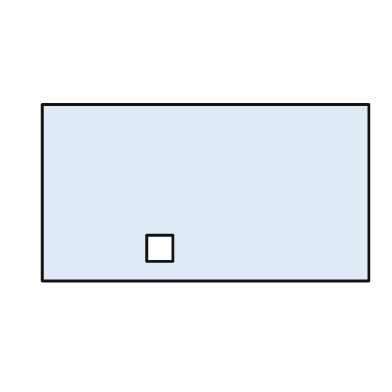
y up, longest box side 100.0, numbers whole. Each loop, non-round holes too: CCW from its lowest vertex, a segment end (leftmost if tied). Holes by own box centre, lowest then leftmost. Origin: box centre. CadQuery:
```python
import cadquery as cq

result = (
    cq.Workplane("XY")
    .moveTo(-50.0, -27.0)
    .lineTo(50.0, -27.0)
    .lineTo(50.0, 27.0)
    .lineTo(-50.0, 27.0)
    .close()
    .moveTo(-18.0, -21.0)
    .lineTo(-10.0, -21.0)
    .lineTo(-10.0, -13.0)
    .lineTo(-18.0, -13.0)
    .close()
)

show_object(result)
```